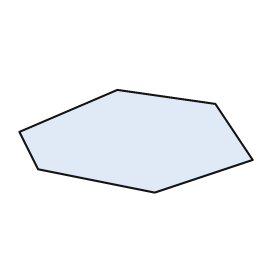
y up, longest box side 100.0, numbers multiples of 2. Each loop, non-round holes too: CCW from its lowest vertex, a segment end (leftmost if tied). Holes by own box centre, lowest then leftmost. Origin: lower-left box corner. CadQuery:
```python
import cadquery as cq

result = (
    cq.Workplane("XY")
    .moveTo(58.0, 0.0)
    .lineTo(100.0, 14.0)
    .lineTo(84.0, 38.0)
    .lineTo(42.0, 44.0)
    .lineTo(0.0, 26.0)
    .lineTo(8.0, 10.0)
    .close()
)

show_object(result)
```